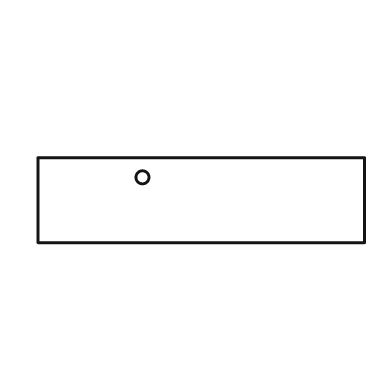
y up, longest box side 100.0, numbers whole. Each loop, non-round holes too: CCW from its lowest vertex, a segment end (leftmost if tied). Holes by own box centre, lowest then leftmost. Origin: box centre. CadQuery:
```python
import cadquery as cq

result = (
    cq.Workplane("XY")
    .moveTo(-50.0, -13.0)
    .lineTo(50.0, -13.0)
    .lineTo(50.0, 13.0)
    .lineTo(-50.0, 13.0)
    .close()
    .moveTo(-18.0, 7.0)
    .circle(2.0)
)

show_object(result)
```